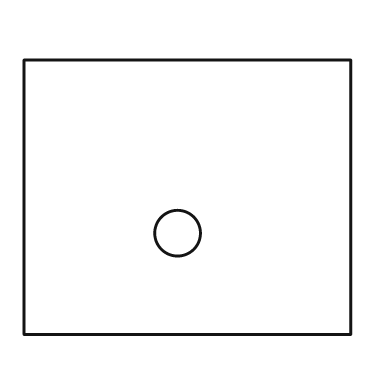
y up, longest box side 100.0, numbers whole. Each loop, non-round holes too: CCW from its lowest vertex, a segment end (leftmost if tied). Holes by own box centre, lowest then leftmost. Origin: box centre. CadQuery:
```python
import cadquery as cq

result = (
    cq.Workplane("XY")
    .moveTo(-50.0, -42.0)
    .lineTo(50.0, -42.0)
    .lineTo(50.0, 42.0)
    .lineTo(-50.0, 42.0)
    .close()
    .moveTo(-3.0, -11.0)
    .circle(7.0)
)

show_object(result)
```